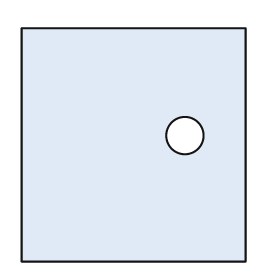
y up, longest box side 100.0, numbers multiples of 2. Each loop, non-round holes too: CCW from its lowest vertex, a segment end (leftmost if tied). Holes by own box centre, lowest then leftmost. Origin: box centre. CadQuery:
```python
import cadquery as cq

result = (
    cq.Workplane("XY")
    .moveTo(-48.0, -50.0)
    .lineTo(48.0, -50.0)
    .lineTo(48.0, 50.0)
    .lineTo(-48.0, 50.0)
    .close()
    .moveTo(22.0, 4.0)
    .circle(8.0)
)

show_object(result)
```